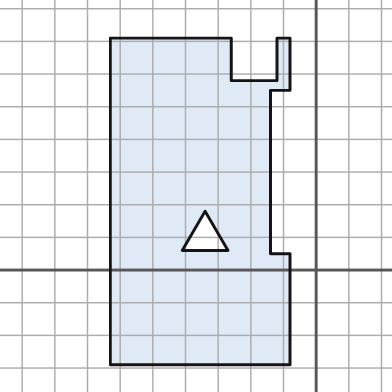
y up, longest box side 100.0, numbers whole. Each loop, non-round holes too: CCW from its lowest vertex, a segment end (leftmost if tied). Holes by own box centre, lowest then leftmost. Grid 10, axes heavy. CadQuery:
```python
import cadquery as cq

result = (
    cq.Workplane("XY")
    .moveTo(-63.0, -29.0)
    .lineTo(-8.0, -29.0)
    .lineTo(-8.0, 5.0)
    .lineTo(-14.0, 5.0)
    .lineTo(-14.0, 55.0)
    .lineTo(-8.0, 55.0)
    .lineTo(-8.0, 71.0)
    .lineTo(-12.0, 71.0)
    .lineTo(-12.0, 58.0)
    .lineTo(-26.0, 58.0)
    .lineTo(-26.0, 71.0)
    .lineTo(-63.0, 71.0)
    .close()
    .moveTo(-41.0, 6.0)
    .lineTo(-27.0, 6.0)
    .lineTo(-34.0, 18.0)
    .close()
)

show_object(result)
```